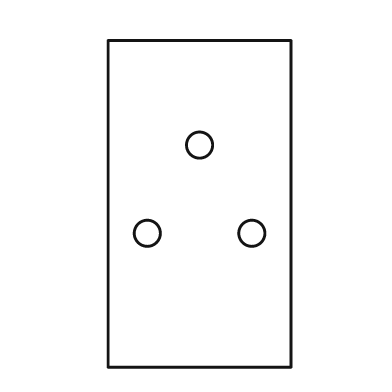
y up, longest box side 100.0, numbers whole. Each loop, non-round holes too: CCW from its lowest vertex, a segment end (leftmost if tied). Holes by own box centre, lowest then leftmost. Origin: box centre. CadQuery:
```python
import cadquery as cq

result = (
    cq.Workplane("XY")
    .moveTo(-28.0, -50.0)
    .lineTo(28.0, -50.0)
    .lineTo(28.0, 50.0)
    .lineTo(-28.0, 50.0)
    .close()
    .moveTo(-16.0, -9.0)
    .circle(4.0)
    .moveTo(16.0, -9.0)
    .circle(4.0)
    .moveTo(0.0, 18.0)
    .circle(4.0)
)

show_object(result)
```